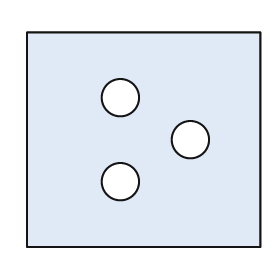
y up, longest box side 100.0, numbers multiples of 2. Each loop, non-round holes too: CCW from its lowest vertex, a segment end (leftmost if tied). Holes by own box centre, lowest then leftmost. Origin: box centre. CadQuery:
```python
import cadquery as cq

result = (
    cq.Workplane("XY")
    .moveTo(-50.0, -46.0)
    .lineTo(50.0, -46.0)
    .lineTo(50.0, 46.0)
    .lineTo(-50.0, 46.0)
    .close()
    .moveTo(-10.0, -18.0)
    .circle(8.0)
    .moveTo(20.0, 0.0)
    .circle(8.0)
    .moveTo(-10.0, 18.0)
    .circle(8.0)
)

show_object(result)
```